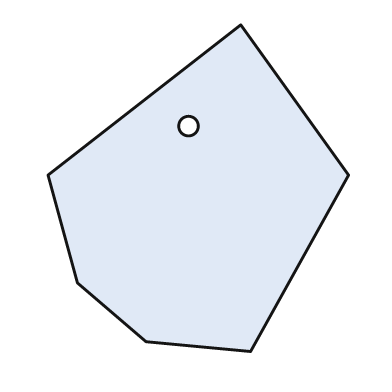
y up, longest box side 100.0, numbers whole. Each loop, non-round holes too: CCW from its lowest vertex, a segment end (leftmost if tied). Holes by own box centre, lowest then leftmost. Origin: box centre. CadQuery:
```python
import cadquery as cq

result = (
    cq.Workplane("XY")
    .moveTo(16.0, -50.0)
    .lineTo(46.0, 4.0)
    .lineTo(13.0, 50.0)
    .lineTo(-46.0, 4.0)
    .lineTo(-37.0, -29.0)
    .lineTo(-16.0, -47.0)
    .close()
    .moveTo(-3.0, 19.0)
    .circle(3.0)
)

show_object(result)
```